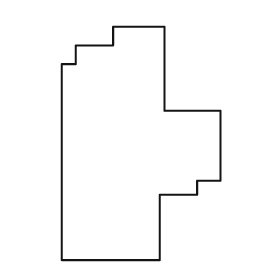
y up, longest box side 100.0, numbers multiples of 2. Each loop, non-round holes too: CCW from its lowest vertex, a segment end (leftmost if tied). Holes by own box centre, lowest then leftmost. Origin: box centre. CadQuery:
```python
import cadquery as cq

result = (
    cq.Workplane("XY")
    .moveTo(-34.0, -50.0)
    .lineTo(8.0, -50.0)
    .lineTo(8.0, -22.0)
    .lineTo(24.0, -22.0)
    .lineTo(24.0, -16.0)
    .lineTo(34.0, -16.0)
    .lineTo(34.0, 14.0)
    .lineTo(10.0, 14.0)
    .lineTo(10.0, 50.0)
    .lineTo(-12.0, 50.0)
    .lineTo(-12.0, 42.0)
    .lineTo(-28.0, 42.0)
    .lineTo(-28.0, 34.0)
    .lineTo(-34.0, 34.0)
    .close()
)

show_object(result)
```